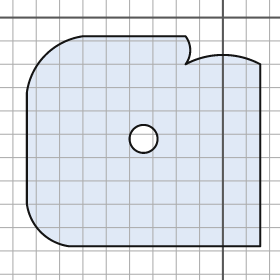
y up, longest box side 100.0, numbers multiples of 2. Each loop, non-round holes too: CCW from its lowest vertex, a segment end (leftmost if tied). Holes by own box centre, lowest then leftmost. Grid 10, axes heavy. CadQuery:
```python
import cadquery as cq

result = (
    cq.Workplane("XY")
    .moveTo(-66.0, -98.0)
    .lineTo(16.0, -98.0)
    .lineTo(16.0, -20.0)
    .threePointArc((0.0, -16.0), (-16.0, -20.0))
    .threePointArc((-14.0, -14.0), (-16.0, -8.0))
    .lineTo(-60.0, -8.0)
    .threePointArc((-76.0, -16.0), (-84.0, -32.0))
    .lineTo(-84.0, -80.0)
    .threePointArc((-78.0, -92.0), (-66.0, -98.0))
    .close()
    .moveTo(-34.0, -52.0)
    .circle(6.0)
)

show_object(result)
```